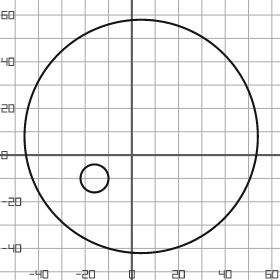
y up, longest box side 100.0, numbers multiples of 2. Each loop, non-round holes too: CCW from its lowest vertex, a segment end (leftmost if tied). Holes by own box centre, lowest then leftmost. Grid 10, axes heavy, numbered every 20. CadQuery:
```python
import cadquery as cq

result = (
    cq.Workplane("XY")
    .moveTo(4.0, 8.0)
    .circle(50.0)
    .moveTo(-16.0, -10.0)
    .circle(6.0)
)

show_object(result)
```